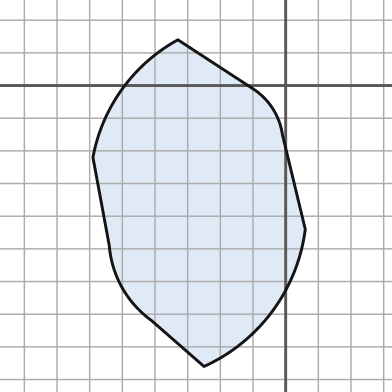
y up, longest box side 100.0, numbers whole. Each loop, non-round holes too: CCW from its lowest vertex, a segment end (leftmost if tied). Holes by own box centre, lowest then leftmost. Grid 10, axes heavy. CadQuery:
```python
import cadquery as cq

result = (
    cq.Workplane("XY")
    .moveTo(-25.0, -86.0)
    .threePointArc((-4.0, -69.0), (6.0, -44.0))
    .lineTo(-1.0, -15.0)
    .threePointArc((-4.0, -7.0), (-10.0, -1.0))
    .lineTo(-33.0, 14.0)
    .threePointArc((-50.0, -1.0), (-59.0, -22.0))
    .lineTo(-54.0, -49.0)
    .threePointArc((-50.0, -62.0), (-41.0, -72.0))
    .close()
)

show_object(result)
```